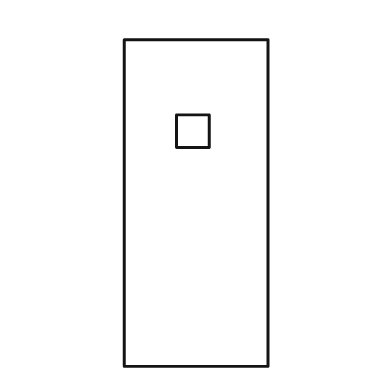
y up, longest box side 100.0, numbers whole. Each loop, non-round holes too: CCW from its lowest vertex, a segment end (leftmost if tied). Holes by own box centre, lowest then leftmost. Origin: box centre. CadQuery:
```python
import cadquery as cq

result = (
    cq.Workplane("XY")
    .moveTo(-22.0, -50.0)
    .lineTo(22.0, -50.0)
    .lineTo(22.0, 50.0)
    .lineTo(-22.0, 50.0)
    .close()
    .moveTo(-6.0, 17.0)
    .lineTo(4.0, 17.0)
    .lineTo(4.0, 27.0)
    .lineTo(-6.0, 27.0)
    .close()
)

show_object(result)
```